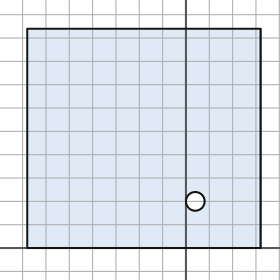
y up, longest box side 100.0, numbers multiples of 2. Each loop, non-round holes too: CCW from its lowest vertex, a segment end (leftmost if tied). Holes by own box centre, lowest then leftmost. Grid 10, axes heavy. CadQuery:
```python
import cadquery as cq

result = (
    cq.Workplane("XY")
    .moveTo(-68.0, 0.0)
    .lineTo(32.0, 0.0)
    .lineTo(32.0, 94.0)
    .lineTo(-68.0, 94.0)
    .close()
    .moveTo(4.0, 20.0)
    .circle(4.0)
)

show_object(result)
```